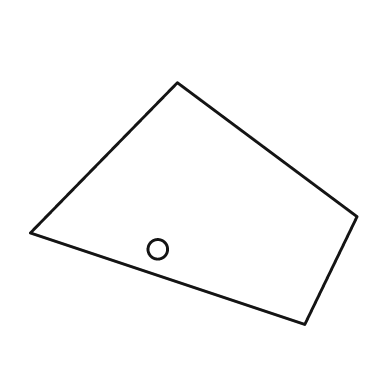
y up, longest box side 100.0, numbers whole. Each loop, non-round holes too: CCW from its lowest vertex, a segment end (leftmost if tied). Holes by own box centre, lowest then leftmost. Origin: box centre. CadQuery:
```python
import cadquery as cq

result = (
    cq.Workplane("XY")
    .moveTo(34.0, -37.0)
    .lineTo(50.0, -4.0)
    .lineTo(-5.0, 37.0)
    .lineTo(-50.0, -9.0)
    .close()
    .moveTo(-11.0, -14.0)
    .circle(3.0)
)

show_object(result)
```